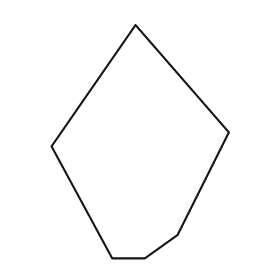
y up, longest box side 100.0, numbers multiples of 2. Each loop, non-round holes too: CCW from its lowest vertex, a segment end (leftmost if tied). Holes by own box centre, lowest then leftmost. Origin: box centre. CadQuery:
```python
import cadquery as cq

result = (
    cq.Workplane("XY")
    .moveTo(-12.0, -50.0)
    .lineTo(2.0, -50.0)
    .lineTo(16.0, -40.0)
    .lineTo(38.0, 4.0)
    .lineTo(-2.0, 50.0)
    .lineTo(-38.0, -2.0)
    .close()
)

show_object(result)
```